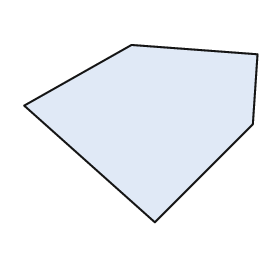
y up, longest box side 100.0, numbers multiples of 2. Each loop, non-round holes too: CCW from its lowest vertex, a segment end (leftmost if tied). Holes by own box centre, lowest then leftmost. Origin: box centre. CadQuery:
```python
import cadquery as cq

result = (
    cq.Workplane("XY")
    .moveTo(6.0, -38.0)
    .lineTo(48.0, 4.0)
    .lineTo(50.0, 34.0)
    .lineTo(-4.0, 38.0)
    .lineTo(-50.0, 12.0)
    .close()
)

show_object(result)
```